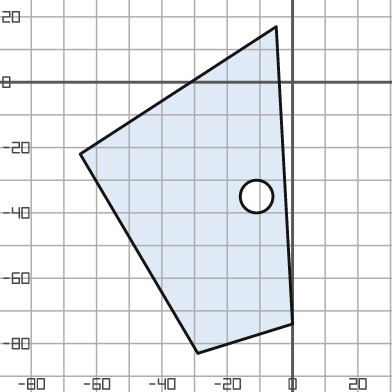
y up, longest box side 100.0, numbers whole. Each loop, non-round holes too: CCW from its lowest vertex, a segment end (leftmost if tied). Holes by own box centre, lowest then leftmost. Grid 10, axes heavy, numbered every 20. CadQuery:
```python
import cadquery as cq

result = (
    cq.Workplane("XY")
    .moveTo(-29.0, -83.0)
    .lineTo(0.0, -74.0)
    .lineTo(-5.0, 17.0)
    .lineTo(-65.0, -22.0)
    .close()
    .moveTo(-11.0, -35.0)
    .circle(5.0)
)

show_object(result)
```